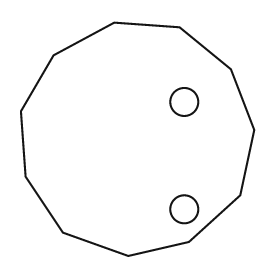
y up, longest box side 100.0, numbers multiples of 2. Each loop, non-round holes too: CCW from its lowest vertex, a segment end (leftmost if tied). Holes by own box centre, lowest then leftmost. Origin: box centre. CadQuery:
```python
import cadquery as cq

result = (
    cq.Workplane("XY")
    .moveTo(-4.0, -50.0)
    .lineTo(22.0, -44.0)
    .lineTo(44.0, -24.0)
    .lineTo(50.0, 4.0)
    .lineTo(40.0, 30.0)
    .lineTo(18.0, 48.0)
    .lineTo(-10.0, 50.0)
    .lineTo(-36.0, 36.0)
    .lineTo(-50.0, 12.0)
    .lineTo(-48.0, -16.0)
    .lineTo(-32.0, -40.0)
    .close()
    .moveTo(20.0, -30.0)
    .circle(6.0)
    .moveTo(20.0, 16.0)
    .circle(6.0)
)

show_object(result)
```